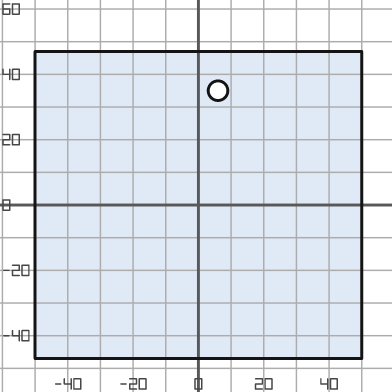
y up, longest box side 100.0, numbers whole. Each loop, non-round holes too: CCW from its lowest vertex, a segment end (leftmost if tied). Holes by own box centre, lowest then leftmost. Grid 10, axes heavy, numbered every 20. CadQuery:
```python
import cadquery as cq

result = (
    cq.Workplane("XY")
    .moveTo(-50.0, -47.0)
    .lineTo(50.0, -47.0)
    .lineTo(50.0, 47.0)
    .lineTo(-50.0, 47.0)
    .close()
    .moveTo(6.0, 35.0)
    .circle(3.0)
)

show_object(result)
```